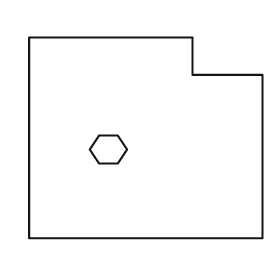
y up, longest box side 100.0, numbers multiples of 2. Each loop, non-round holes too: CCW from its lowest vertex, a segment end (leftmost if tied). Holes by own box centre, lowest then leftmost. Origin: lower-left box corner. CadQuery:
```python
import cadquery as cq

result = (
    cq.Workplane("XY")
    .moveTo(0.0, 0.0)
    .lineTo(100.0, 0.0)
    .lineTo(100.0, 70.0)
    .lineTo(70.0, 70.0)
    .lineTo(70.0, 86.0)
    .lineTo(0.0, 86.0)
    .close()
    .moveTo(30.0, 32.0)
    .lineTo(38.0, 32.0)
    .lineTo(42.0, 38.0)
    .lineTo(38.0, 44.0)
    .lineTo(30.0, 44.0)
    .lineTo(26.0, 38.0)
    .close()
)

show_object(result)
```